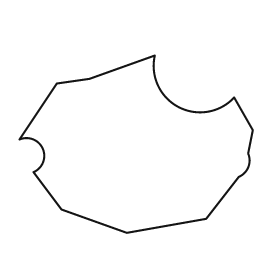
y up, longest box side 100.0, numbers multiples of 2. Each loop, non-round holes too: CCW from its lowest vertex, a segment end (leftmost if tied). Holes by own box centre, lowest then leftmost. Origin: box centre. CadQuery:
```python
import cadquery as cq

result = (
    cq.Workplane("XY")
    .moveTo(-4.0, -38.0)
    .lineTo(30.0, -32.0)
    .lineTo(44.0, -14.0)
    .threePointArc((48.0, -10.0), (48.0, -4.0))
    .lineTo(50.0, 6.0)
    .lineTo(42.0, 20.0)
    .threePointArc((18.0, 16.0), (8.0, 38.0))
    .lineTo(-20.0, 28.0)
    .lineTo(-34.0, 26.0)
    .lineTo(-50.0, 2.0)
    .threePointArc((-40.0, -2.0), (-44.0, -12.0))
    .lineTo(-32.0, -28.0)
    .close()
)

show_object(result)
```